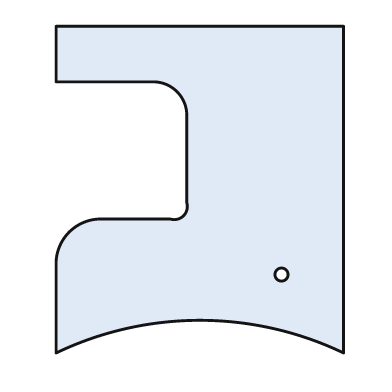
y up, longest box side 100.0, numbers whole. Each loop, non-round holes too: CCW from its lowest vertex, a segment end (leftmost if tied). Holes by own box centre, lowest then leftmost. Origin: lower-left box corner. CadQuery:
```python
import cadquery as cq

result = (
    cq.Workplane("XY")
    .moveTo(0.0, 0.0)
    .threePointArc((44.0, 10.0), (88.0, 0.0))
    .lineTo(88.0, 100.0)
    .lineTo(0.0, 100.0)
    .lineTo(0.0, 83.0)
    .lineTo(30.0, 83.0)
    .threePointArc((37.0, 80.0), (40.0, 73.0))
    .lineTo(40.0, 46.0)
    .threePointArc((39.0, 42.0), (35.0, 41.0))
    .lineTo(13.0, 41.0)
    .threePointArc((4.0, 37.0), (0.0, 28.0))
    .close()
    .moveTo(69.0, 24.0)
    .circle(2.0)
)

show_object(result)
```